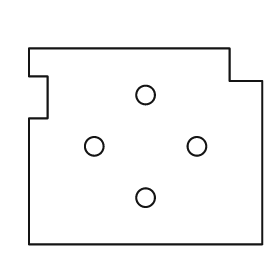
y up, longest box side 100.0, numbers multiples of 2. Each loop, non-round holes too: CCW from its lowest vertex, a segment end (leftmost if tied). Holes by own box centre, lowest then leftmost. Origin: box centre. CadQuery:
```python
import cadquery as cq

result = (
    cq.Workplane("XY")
    .moveTo(-50.0, -42.0)
    .lineTo(50.0, -42.0)
    .lineTo(50.0, 28.0)
    .lineTo(36.0, 28.0)
    .lineTo(36.0, 42.0)
    .lineTo(-50.0, 42.0)
    .lineTo(-50.0, 30.0)
    .lineTo(-42.0, 30.0)
    .lineTo(-42.0, 12.0)
    .lineTo(-50.0, 12.0)
    .close()
    .moveTo(0.0, -22.0)
    .circle(4.0)
    .moveTo(-22.0, 0.0)
    .circle(4.0)
    .moveTo(22.0, 0.0)
    .circle(4.0)
    .moveTo(0.0, 22.0)
    .circle(4.0)
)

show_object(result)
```